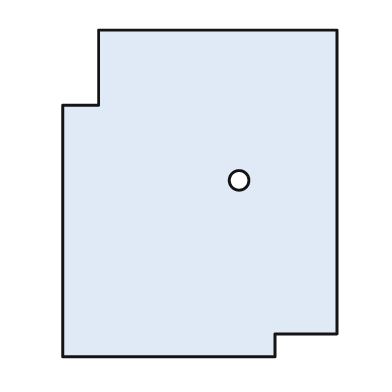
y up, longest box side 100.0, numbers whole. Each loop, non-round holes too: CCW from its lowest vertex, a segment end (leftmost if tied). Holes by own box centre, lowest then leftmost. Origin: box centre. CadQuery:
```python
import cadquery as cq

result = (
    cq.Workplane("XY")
    .moveTo(-42.0, -50.0)
    .lineTo(23.0, -50.0)
    .lineTo(23.0, -43.0)
    .lineTo(42.0, -43.0)
    .lineTo(42.0, 50.0)
    .lineTo(-31.0, 50.0)
    .lineTo(-31.0, 27.0)
    .lineTo(-42.0, 27.0)
    .close()
    .moveTo(12.0, 4.0)
    .circle(3.0)
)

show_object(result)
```